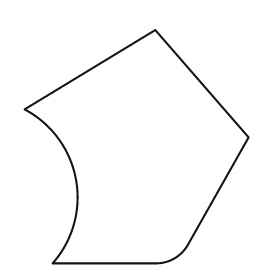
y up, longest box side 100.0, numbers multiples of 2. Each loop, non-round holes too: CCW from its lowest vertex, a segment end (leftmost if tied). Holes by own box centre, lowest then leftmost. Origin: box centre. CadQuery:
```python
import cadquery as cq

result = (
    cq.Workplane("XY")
    .moveTo(-36.0, -50.0)
    .lineTo(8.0, -50.0)
    .threePointArc((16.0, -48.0), (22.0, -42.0))
    .lineTo(48.0, 4.0)
    .lineTo(8.0, 50.0)
    .lineTo(-48.0, 16.0)
    .threePointArc((-26.0, -14.0), (-36.0, -50.0))
    .close()
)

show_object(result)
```